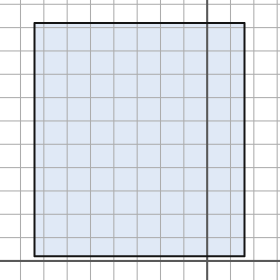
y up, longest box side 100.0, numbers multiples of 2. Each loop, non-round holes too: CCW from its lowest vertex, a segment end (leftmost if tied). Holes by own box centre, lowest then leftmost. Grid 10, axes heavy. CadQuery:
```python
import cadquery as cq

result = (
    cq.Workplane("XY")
    .moveTo(-74.0, 2.0)
    .lineTo(16.0, 2.0)
    .lineTo(16.0, 102.0)
    .lineTo(-74.0, 102.0)
    .close()
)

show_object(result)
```